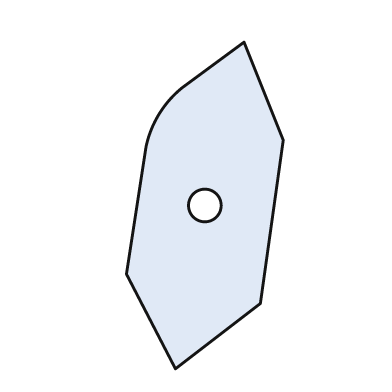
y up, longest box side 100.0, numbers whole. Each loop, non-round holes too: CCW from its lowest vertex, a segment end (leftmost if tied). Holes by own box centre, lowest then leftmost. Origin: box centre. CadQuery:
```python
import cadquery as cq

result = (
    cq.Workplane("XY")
    .moveTo(-9.0, -50.0)
    .lineTo(17.0, -30.0)
    .lineTo(24.0, 20.0)
    .lineTo(12.0, 50.0)
    .lineTo(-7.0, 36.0)
    .threePointArc((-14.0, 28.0), (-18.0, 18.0))
    .lineTo(-24.0, -21.0)
    .close()
    .moveTo(0.0, 0.0)
    .circle(5.0)
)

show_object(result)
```